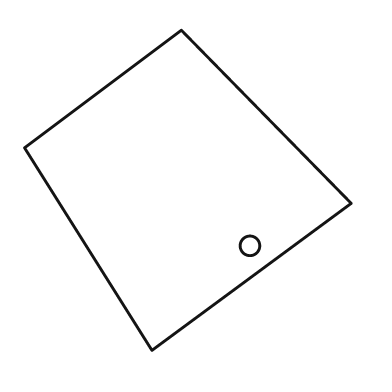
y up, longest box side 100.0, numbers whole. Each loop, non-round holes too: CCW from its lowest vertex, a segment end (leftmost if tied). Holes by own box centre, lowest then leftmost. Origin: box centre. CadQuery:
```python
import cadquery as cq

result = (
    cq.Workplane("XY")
    .moveTo(-11.0, -49.0)
    .lineTo(50.0, -4.0)
    .lineTo(-2.0, 49.0)
    .lineTo(-50.0, 13.0)
    .close()
    .moveTo(19.0, -17.0)
    .circle(3.0)
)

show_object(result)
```